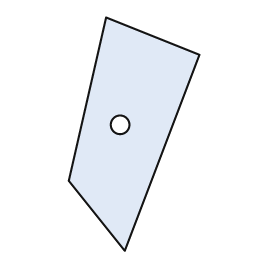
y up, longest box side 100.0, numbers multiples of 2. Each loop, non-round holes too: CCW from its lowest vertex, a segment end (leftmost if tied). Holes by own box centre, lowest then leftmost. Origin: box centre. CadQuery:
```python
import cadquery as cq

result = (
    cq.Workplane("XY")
    .moveTo(-4.0, -50.0)
    .lineTo(28.0, 34.0)
    .lineTo(-12.0, 50.0)
    .lineTo(-28.0, -20.0)
    .close()
    .moveTo(-6.0, 4.0)
    .circle(4.0)
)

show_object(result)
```